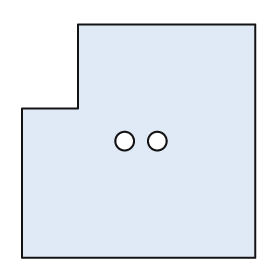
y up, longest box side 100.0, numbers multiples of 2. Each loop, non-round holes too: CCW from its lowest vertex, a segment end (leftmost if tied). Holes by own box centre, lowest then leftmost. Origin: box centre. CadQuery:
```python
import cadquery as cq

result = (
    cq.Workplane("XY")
    .moveTo(-50.0, -50.0)
    .lineTo(50.0, -50.0)
    .lineTo(50.0, 50.0)
    .lineTo(-26.0, 50.0)
    .lineTo(-26.0, 14.0)
    .lineTo(-50.0, 14.0)
    .close()
    .moveTo(-6.0, 0.0)
    .circle(4.0)
    .moveTo(8.0, 0.0)
    .circle(4.0)
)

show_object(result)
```